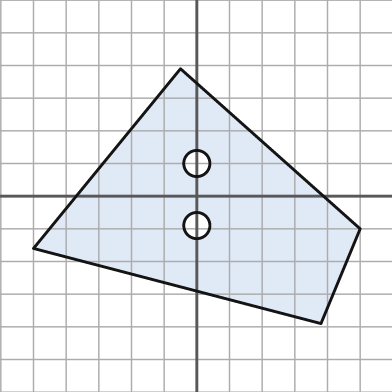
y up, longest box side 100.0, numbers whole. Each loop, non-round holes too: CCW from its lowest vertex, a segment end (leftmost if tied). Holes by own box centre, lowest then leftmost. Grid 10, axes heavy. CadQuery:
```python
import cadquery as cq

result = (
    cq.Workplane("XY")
    .moveTo(38.0, -39.0)
    .lineTo(50.0, -10.0)
    .lineTo(-5.0, 39.0)
    .lineTo(-50.0, -16.0)
    .close()
    .moveTo(0.0, -9.0)
    .circle(4.0)
    .moveTo(0.0, 10.0)
    .circle(4.0)
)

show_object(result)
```